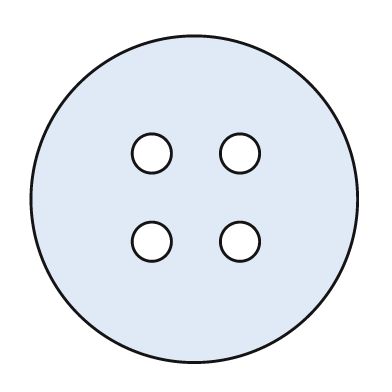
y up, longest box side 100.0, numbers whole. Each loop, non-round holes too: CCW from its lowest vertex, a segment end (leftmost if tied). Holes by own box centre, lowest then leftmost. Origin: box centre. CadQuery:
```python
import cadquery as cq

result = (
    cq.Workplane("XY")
    .moveTo(0.0, 0.0)
    .circle(50.0)
    .moveTo(-13.0, -13.0)
    .circle(6.0)
    .moveTo(14.0, -13.0)
    .circle(6.0)
    .moveTo(-13.0, 14.0)
    .circle(6.0)
    .moveTo(14.0, 14.0)
    .circle(6.0)
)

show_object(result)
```